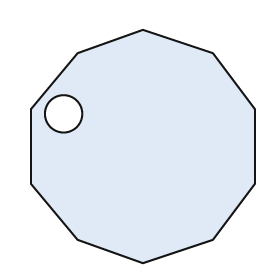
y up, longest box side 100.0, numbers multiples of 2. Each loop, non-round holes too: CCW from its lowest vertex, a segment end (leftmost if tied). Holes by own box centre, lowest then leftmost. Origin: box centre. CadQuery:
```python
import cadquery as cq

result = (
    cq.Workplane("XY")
    .moveTo(0.0, -50.0)
    .lineTo(30.0, -40.0)
    .lineTo(48.0, -16.0)
    .lineTo(48.0, 16.0)
    .lineTo(30.0, 40.0)
    .lineTo(0.0, 50.0)
    .lineTo(-28.0, 40.0)
    .lineTo(-48.0, 16.0)
    .lineTo(-48.0, -16.0)
    .lineTo(-28.0, -40.0)
    .close()
    .moveTo(-34.0, 14.0)
    .circle(8.0)
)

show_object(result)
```